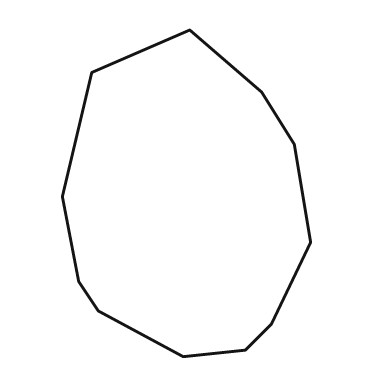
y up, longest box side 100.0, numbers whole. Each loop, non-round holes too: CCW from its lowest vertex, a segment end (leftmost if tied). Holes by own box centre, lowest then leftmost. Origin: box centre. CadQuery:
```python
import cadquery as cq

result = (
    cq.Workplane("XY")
    .moveTo(-1.0, -50.0)
    .lineTo(18.0, -48.0)
    .lineTo(26.0, -40.0)
    .lineTo(38.0, -15.0)
    .lineTo(33.0, 15.0)
    .lineTo(23.0, 31.0)
    .lineTo(1.0, 50.0)
    .lineTo(-29.0, 37.0)
    .lineTo(-38.0, -1.0)
    .lineTo(-33.0, -27.0)
    .lineTo(-27.0, -36.0)
    .close()
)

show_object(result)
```